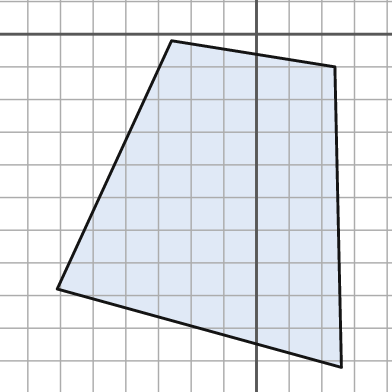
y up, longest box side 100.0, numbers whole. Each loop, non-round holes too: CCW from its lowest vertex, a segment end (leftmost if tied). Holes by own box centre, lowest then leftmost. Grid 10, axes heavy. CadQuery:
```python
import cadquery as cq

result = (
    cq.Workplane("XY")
    .moveTo(26.0, -102.0)
    .lineTo(24.0, -10.0)
    .lineTo(-26.0, -2.0)
    .lineTo(-61.0, -78.0)
    .close()
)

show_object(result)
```